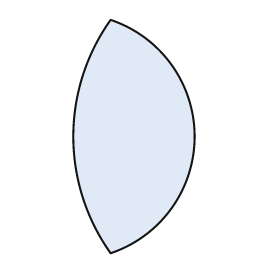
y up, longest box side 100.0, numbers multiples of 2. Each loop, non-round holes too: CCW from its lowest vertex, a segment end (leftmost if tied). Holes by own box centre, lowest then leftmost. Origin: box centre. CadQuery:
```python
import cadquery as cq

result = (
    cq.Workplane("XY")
    .moveTo(-10.0, -50.0)
    .threePointArc((26.0, 0.0), (-10.0, 50.0))
    .threePointArc((-26.0, 0.0), (-10.0, -50.0))
    .close()
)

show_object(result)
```